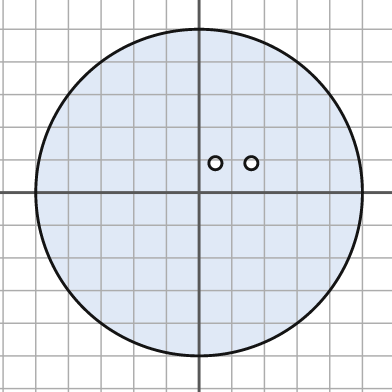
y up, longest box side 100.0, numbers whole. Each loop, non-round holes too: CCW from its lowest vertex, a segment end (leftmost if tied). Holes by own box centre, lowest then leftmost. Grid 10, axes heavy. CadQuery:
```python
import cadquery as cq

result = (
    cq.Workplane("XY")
    .moveTo(0.0, 0.0)
    .circle(50.0)
    .moveTo(5.0, 9.0)
    .circle(2.0)
    .moveTo(16.0, 9.0)
    .circle(2.0)
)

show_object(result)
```